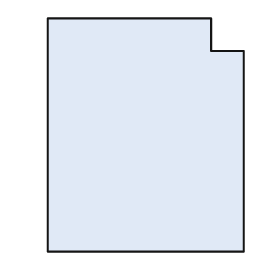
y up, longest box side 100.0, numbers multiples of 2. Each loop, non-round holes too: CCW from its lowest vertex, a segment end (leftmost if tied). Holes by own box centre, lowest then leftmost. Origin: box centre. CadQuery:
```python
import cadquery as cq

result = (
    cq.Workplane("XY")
    .moveTo(-42.0, -50.0)
    .lineTo(42.0, -50.0)
    .lineTo(42.0, 36.0)
    .lineTo(28.0, 36.0)
    .lineTo(28.0, 50.0)
    .lineTo(-42.0, 50.0)
    .close()
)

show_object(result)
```